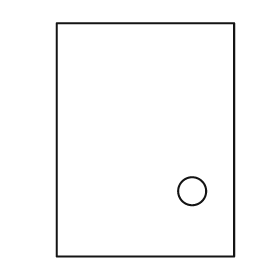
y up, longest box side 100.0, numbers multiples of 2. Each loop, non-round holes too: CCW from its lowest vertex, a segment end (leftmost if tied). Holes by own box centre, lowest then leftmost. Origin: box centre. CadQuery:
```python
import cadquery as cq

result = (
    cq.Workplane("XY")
    .moveTo(-38.0, -50.0)
    .lineTo(38.0, -50.0)
    .lineTo(38.0, 50.0)
    .lineTo(-38.0, 50.0)
    .close()
    .moveTo(20.0, -22.0)
    .circle(6.0)
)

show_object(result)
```